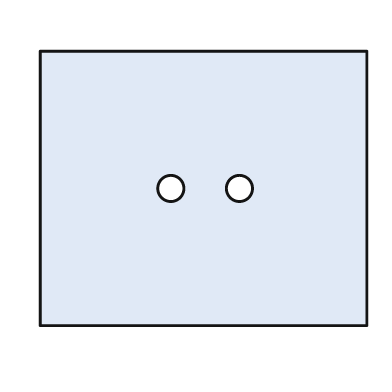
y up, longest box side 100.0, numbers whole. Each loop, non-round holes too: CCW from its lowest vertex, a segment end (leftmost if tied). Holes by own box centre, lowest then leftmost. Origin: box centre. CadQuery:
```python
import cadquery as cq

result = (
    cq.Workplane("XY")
    .moveTo(-50.0, -42.0)
    .lineTo(50.0, -42.0)
    .lineTo(50.0, 42.0)
    .lineTo(-50.0, 42.0)
    .close()
    .moveTo(-10.0, 0.0)
    .circle(4.0)
    .moveTo(11.0, 0.0)
    .circle(4.0)
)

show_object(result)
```